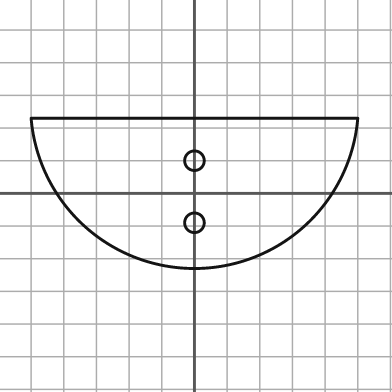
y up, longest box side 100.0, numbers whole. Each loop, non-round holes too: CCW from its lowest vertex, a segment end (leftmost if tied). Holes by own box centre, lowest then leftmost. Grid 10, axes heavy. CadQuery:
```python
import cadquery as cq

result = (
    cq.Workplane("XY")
    .moveTo(-50.0, 23.0)
    .threePointArc((0.0, -23.0), (50.0, 23.0))
    .close()
    .moveTo(0.0, -9.0)
    .circle(3.0)
    .moveTo(0.0, 10.0)
    .circle(3.0)
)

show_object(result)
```